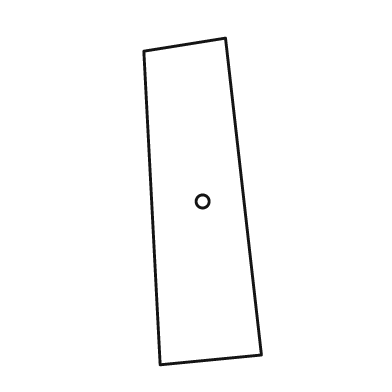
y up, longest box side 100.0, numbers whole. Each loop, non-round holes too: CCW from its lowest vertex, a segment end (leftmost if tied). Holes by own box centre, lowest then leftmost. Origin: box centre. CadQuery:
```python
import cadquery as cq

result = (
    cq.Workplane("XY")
    .moveTo(-13.0, -50.0)
    .lineTo(18.0, -47.0)
    .lineTo(7.0, 50.0)
    .lineTo(-18.0, 46.0)
    .close()
    .moveTo(0.0, 0.0)
    .circle(2.0)
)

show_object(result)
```